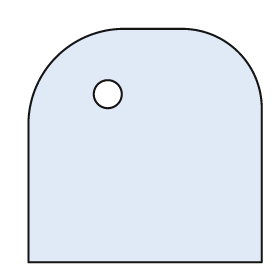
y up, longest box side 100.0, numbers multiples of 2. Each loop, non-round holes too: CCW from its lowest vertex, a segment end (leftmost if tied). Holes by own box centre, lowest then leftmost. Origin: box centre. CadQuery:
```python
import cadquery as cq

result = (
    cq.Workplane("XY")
    .moveTo(-50.0, -50.0)
    .lineTo(50.0, -50.0)
    .lineTo(50.0, 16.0)
    .threePointArc((40.0, 40.0), (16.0, 50.0))
    .lineTo(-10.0, 50.0)
    .threePointArc((-38.0, 38.0), (-50.0, 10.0))
    .close()
    .moveTo(-16.0, 22.0)
    .circle(6.0)
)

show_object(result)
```